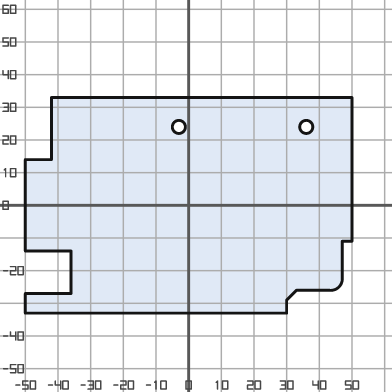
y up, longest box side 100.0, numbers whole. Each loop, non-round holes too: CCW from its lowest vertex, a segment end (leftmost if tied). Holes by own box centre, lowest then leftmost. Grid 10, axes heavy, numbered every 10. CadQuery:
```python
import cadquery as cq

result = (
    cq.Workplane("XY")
    .moveTo(-50.0, -33.0)
    .lineTo(30.0, -33.0)
    .lineTo(30.0, -29.0)
    .lineTo(33.0, -26.0)
    .lineTo(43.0, -26.0)
    .threePointArc((46.0, -25.0), (47.0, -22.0))
    .lineTo(47.0, -11.0)
    .lineTo(50.0, -11.0)
    .lineTo(50.0, 33.0)
    .lineTo(-42.0, 33.0)
    .lineTo(-42.0, 14.0)
    .lineTo(-50.0, 14.0)
    .lineTo(-50.0, -14.0)
    .lineTo(-36.0, -14.0)
    .lineTo(-36.0, -27.0)
    .lineTo(-50.0, -27.0)
    .close()
    .moveTo(-3.0, 24.0)
    .circle(2.0)
    .moveTo(36.0, 24.0)
    .circle(2.0)
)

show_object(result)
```